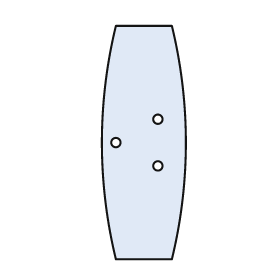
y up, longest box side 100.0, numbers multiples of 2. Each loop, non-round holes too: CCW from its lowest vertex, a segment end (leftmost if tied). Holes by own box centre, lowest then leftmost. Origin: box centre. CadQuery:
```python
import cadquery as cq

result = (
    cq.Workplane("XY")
    .moveTo(-12.0, -50.0)
    .lineTo(12.0, -50.0)
    .threePointArc((18.0, 0.0), (12.0, 50.0))
    .lineTo(-12.0, 50.0)
    .threePointArc((-18.0, 0.0), (-12.0, -50.0))
    .close()
    .moveTo(6.0, -10.0)
    .circle(2.0)
    .moveTo(-12.0, 0.0)
    .circle(2.0)
    .moveTo(6.0, 10.0)
    .circle(2.0)
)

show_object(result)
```